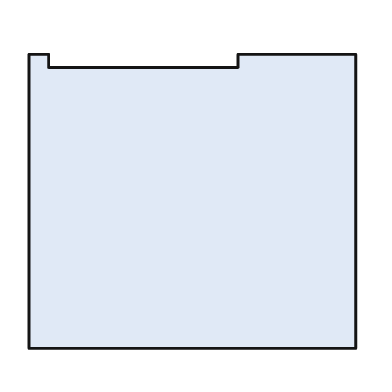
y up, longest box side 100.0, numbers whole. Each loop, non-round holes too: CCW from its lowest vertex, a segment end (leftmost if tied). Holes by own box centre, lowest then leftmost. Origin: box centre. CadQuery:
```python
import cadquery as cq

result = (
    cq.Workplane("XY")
    .moveTo(-50.0, -45.0)
    .lineTo(50.0, -45.0)
    .lineTo(50.0, 45.0)
    .lineTo(14.0, 45.0)
    .lineTo(14.0, 41.0)
    .lineTo(-44.0, 41.0)
    .lineTo(-44.0, 45.0)
    .lineTo(-50.0, 45.0)
    .close()
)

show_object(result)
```